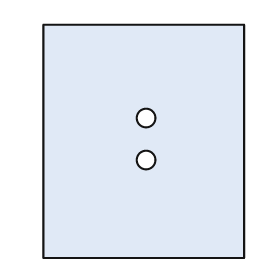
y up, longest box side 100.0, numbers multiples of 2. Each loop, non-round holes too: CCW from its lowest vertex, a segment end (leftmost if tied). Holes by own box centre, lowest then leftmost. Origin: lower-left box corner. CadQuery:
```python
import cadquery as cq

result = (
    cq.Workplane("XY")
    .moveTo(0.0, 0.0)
    .lineTo(86.0, 0.0)
    .lineTo(86.0, 100.0)
    .lineTo(0.0, 100.0)
    .close()
    .moveTo(44.0, 42.0)
    .circle(4.0)
    .moveTo(44.0, 60.0)
    .circle(4.0)
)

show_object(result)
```